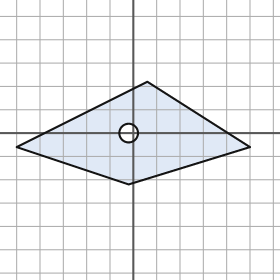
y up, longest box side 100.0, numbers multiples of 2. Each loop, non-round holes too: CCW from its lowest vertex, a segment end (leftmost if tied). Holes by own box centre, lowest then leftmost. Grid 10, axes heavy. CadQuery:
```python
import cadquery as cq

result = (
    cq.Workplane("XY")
    .moveTo(-2.0, -22.0)
    .lineTo(50.0, -6.0)
    .lineTo(6.0, 22.0)
    .lineTo(-50.0, -6.0)
    .close()
    .moveTo(-2.0, 0.0)
    .circle(4.0)
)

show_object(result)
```